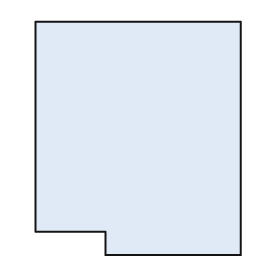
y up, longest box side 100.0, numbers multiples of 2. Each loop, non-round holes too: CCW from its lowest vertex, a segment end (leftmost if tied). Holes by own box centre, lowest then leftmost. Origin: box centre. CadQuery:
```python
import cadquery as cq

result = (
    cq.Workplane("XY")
    .moveTo(-14.0, -50.0)
    .lineTo(44.0, -50.0)
    .lineTo(44.0, 50.0)
    .lineTo(-44.0, 50.0)
    .lineTo(-44.0, -40.0)
    .lineTo(-14.0, -40.0)
    .close()
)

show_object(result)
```